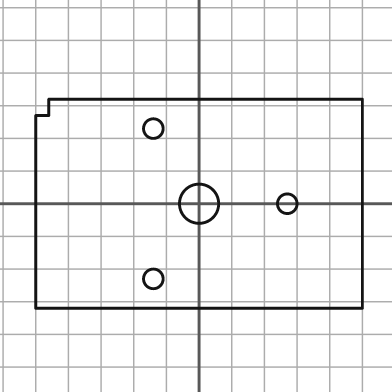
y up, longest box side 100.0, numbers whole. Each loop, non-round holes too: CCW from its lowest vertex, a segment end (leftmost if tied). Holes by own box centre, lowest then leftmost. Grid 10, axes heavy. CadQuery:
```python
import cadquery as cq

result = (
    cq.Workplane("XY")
    .moveTo(-50.0, -32.0)
    .lineTo(50.0, -32.0)
    .lineTo(50.0, 32.0)
    .lineTo(-46.0, 32.0)
    .lineTo(-46.0, 27.0)
    .lineTo(-50.0, 27.0)
    .close()
    .moveTo(-14.0, -23.0)
    .circle(3.0)
    .moveTo(0.0, 0.0)
    .circle(6.0)
    .moveTo(27.0, 0.0)
    .circle(3.0)
    .moveTo(-14.0, 23.0)
    .circle(3.0)
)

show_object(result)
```